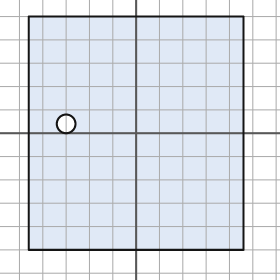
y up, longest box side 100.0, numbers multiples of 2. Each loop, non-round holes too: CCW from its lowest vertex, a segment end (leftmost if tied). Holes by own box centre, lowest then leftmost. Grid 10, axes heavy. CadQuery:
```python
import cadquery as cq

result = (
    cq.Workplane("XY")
    .moveTo(-46.0, -50.0)
    .lineTo(46.0, -50.0)
    .lineTo(46.0, 50.0)
    .lineTo(-46.0, 50.0)
    .close()
    .moveTo(-30.0, 4.0)
    .circle(4.0)
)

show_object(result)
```